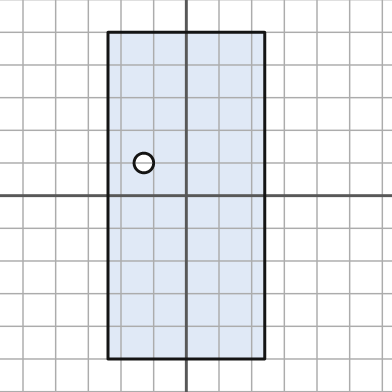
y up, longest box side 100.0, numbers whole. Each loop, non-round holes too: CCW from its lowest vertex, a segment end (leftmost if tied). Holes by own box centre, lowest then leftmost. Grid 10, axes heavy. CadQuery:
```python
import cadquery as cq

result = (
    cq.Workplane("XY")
    .moveTo(-24.0, -50.0)
    .lineTo(24.0, -50.0)
    .lineTo(24.0, 50.0)
    .lineTo(-24.0, 50.0)
    .close()
    .moveTo(-13.0, 10.0)
    .circle(3.0)
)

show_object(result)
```